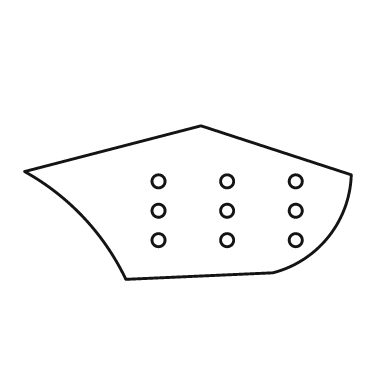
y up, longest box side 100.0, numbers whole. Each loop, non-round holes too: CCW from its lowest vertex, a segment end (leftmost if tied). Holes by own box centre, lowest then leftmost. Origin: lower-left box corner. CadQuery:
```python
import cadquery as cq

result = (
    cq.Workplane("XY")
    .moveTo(31.0, 0.0)
    .lineTo(76.0, 2.0)
    .threePointArc((93.0, 13.0), (100.0, 32.0))
    .lineTo(54.0, 47.0)
    .lineTo(0.0, 33.0)
    .threePointArc((18.0, 19.0), (31.0, 0.0))
    .close()
    .moveTo(41.0, 12.0)
    .circle(2.0)
    .moveTo(62.0, 12.0)
    .circle(2.0)
    .moveTo(83.0, 12.0)
    .circle(2.0)
    .moveTo(41.0, 21.0)
    .circle(2.0)
    .moveTo(62.0, 21.0)
    .circle(2.0)
    .moveTo(83.0, 21.0)
    .circle(2.0)
    .moveTo(41.0, 30.0)
    .circle(2.0)
    .moveTo(62.0, 30.0)
    .circle(2.0)
    .moveTo(83.0, 30.0)
    .circle(2.0)
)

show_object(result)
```